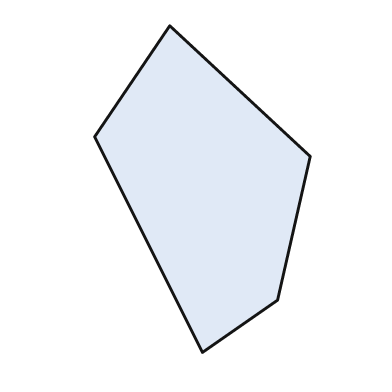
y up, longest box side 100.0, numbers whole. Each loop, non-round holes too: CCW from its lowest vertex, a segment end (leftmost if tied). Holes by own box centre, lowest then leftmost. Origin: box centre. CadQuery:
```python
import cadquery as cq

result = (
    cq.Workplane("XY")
    .moveTo(0.0, -50.0)
    .lineTo(23.0, -34.0)
    .lineTo(33.0, 10.0)
    .lineTo(-10.0, 50.0)
    .lineTo(-33.0, 16.0)
    .close()
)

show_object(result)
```